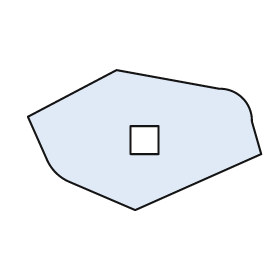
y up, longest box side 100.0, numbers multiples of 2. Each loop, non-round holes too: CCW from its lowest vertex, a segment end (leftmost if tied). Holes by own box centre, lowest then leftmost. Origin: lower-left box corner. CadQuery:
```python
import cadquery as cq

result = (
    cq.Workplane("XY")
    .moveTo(46.0, 0.0)
    .lineTo(100.0, 24.0)
    .lineTo(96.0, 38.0)
    .threePointArc((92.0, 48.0), (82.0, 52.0))
    .lineTo(38.0, 60.0)
    .lineTo(0.0, 40.0)
    .lineTo(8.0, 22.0)
    .threePointArc((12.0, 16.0), (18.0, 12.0))
    .close()
    .moveTo(44.0, 24.0)
    .lineTo(56.0, 24.0)
    .lineTo(56.0, 36.0)
    .lineTo(44.0, 36.0)
    .close()
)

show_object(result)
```